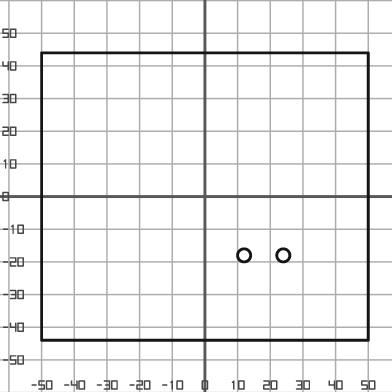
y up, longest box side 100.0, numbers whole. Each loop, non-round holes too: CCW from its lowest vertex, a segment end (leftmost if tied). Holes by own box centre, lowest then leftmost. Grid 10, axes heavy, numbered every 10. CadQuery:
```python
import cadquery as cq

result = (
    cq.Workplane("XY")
    .moveTo(-50.0, -44.0)
    .lineTo(50.0, -44.0)
    .lineTo(50.0, 44.0)
    .lineTo(-50.0, 44.0)
    .close()
    .moveTo(12.0, -18.0)
    .circle(2.0)
    .moveTo(24.0, -18.0)
    .circle(2.0)
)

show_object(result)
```